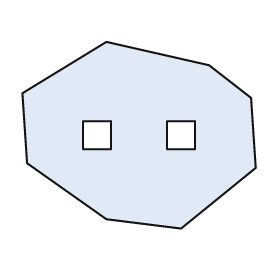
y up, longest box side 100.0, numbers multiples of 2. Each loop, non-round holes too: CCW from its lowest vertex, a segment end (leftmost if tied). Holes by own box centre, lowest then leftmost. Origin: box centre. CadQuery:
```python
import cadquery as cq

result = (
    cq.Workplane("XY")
    .moveTo(18.0, -40.0)
    .lineTo(50.0, -14.0)
    .lineTo(48.0, 16.0)
    .lineTo(30.0, 30.0)
    .lineTo(-14.0, 40.0)
    .lineTo(-50.0, 18.0)
    .lineTo(-48.0, -12.0)
    .lineTo(-14.0, -36.0)
    .close()
    .moveTo(-24.0, -6.0)
    .lineTo(-12.0, -6.0)
    .lineTo(-12.0, 6.0)
    .lineTo(-24.0, 6.0)
    .close()
    .moveTo(12.0, -6.0)
    .lineTo(24.0, -6.0)
    .lineTo(24.0, 6.0)
    .lineTo(12.0, 6.0)
    .close()
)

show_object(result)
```